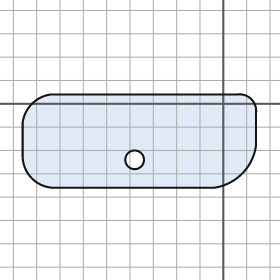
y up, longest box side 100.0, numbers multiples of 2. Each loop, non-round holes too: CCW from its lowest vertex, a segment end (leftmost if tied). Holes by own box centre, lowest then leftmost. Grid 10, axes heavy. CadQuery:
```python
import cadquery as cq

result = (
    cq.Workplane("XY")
    .moveTo(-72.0, -36.0)
    .lineTo(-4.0, -36.0)
    .threePointArc((8.0, -30.0), (14.0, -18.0))
    .lineTo(14.0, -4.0)
    .threePointArc((12.0, 2.0), (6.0, 4.0))
    .lineTo(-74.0, 4.0)
    .threePointArc((-82.0, 0.0), (-86.0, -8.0))
    .lineTo(-86.0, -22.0)
    .threePointArc((-82.0, -32.0), (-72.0, -36.0))
    .close()
    .moveTo(-38.0, -24.0)
    .circle(4.0)
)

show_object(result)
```